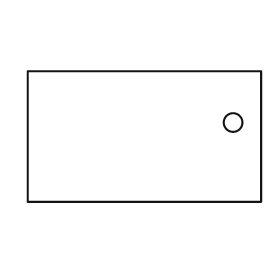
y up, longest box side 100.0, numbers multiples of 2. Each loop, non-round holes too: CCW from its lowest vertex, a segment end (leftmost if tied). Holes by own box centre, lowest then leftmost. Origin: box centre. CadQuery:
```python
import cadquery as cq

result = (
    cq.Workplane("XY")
    .moveTo(-50.0, -28.0)
    .lineTo(50.0, -28.0)
    .lineTo(50.0, 28.0)
    .lineTo(-50.0, 28.0)
    .close()
    .moveTo(38.0, 6.0)
    .circle(4.0)
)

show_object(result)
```